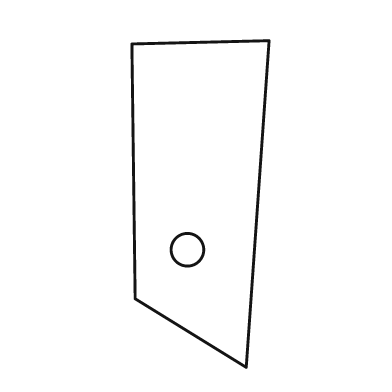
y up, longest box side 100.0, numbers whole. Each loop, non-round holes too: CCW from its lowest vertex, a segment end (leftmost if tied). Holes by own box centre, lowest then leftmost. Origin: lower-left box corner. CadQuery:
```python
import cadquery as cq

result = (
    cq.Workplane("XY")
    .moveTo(35.0, 0.0)
    .lineTo(42.0, 100.0)
    .lineTo(0.0, 99.0)
    .lineTo(1.0, 21.0)
    .close()
    .moveTo(17.0, 36.0)
    .circle(5.0)
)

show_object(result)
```